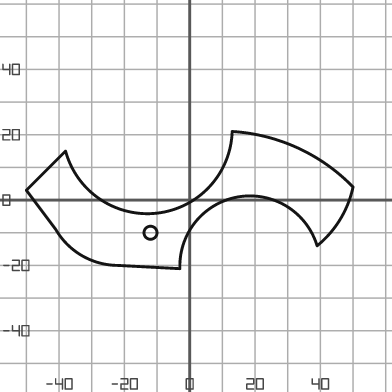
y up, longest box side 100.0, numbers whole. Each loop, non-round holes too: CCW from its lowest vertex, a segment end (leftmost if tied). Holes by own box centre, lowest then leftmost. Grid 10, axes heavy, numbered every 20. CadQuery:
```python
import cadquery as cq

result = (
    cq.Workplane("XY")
    .moveTo(-3.0, -21.0)
    .threePointArc((15.0, 1.0), (39.0, -14.0))
    .threePointArc((46.0, -6.0), (50.0, 4.0))
    .threePointArc((33.0, 16.0), (13.0, 21.0))
    .threePointArc((-10.0, -4.0), (-38.0, 15.0))
    .lineTo(-50.0, 3.0)
    .lineTo(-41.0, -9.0)
    .threePointArc((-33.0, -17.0), (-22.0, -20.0))
    .close()
    .moveTo(-12.0, -10.0)
    .circle(2.0)
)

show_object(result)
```